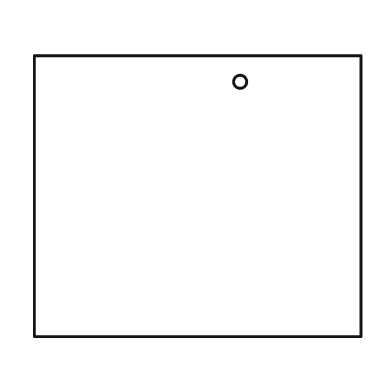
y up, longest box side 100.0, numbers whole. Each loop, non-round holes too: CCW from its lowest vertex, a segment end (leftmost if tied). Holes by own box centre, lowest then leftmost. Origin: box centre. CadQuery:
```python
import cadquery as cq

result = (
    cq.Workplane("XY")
    .moveTo(-50.0, -43.0)
    .lineTo(50.0, -43.0)
    .lineTo(50.0, 43.0)
    .lineTo(-50.0, 43.0)
    .close()
    .moveTo(13.0, 35.0)
    .circle(2.0)
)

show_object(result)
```